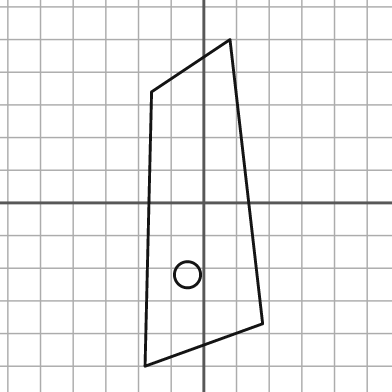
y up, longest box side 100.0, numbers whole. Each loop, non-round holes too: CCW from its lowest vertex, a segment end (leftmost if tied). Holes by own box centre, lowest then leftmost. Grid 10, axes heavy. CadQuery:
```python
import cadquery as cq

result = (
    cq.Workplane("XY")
    .moveTo(-18.0, -50.0)
    .lineTo(18.0, -37.0)
    .lineTo(8.0, 50.0)
    .lineTo(-16.0, 34.0)
    .close()
    .moveTo(-5.0, -22.0)
    .circle(4.0)
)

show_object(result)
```